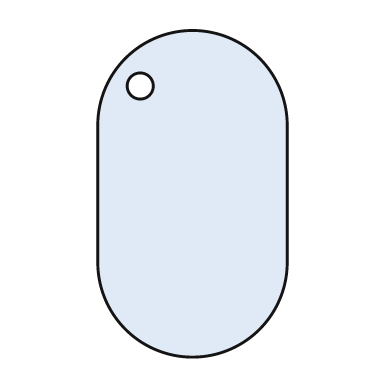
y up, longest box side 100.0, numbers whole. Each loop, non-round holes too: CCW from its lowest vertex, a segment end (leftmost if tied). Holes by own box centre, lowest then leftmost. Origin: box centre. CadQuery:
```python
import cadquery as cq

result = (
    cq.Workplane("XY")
    .moveTo(-29.0, -21.0)
    .threePointArc((0.0, -50.0), (29.0, -21.0))
    .lineTo(29.0, 21.0)
    .threePointArc((0.0, 50.0), (-29.0, 21.0))
    .close()
    .moveTo(-16.0, 33.0)
    .circle(4.0)
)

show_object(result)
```